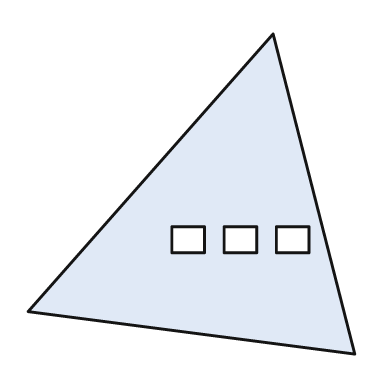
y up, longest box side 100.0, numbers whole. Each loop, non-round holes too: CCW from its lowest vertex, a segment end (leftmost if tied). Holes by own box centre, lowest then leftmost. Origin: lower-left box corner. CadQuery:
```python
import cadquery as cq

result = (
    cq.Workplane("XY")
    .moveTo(100.0, 0.0)
    .lineTo(75.0, 98.0)
    .lineTo(0.0, 13.0)
    .close()
    .moveTo(44.0, 31.0)
    .lineTo(54.0, 31.0)
    .lineTo(54.0, 39.0)
    .lineTo(44.0, 39.0)
    .close()
    .moveTo(60.0, 31.0)
    .lineTo(70.0, 31.0)
    .lineTo(70.0, 39.0)
    .lineTo(60.0, 39.0)
    .close()
    .moveTo(76.0, 31.0)
    .lineTo(86.0, 31.0)
    .lineTo(86.0, 39.0)
    .lineTo(76.0, 39.0)
    .close()
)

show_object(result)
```